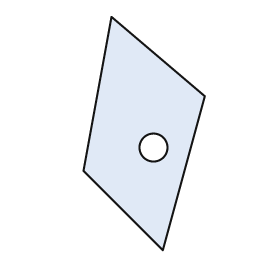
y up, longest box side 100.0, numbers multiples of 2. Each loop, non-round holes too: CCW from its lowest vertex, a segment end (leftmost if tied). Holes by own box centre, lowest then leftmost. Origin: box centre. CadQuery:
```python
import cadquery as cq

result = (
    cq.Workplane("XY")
    .moveTo(8.0, -50.0)
    .lineTo(26.0, 16.0)
    .lineTo(-14.0, 50.0)
    .lineTo(-26.0, -16.0)
    .close()
    .moveTo(4.0, -6.0)
    .circle(6.0)
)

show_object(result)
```